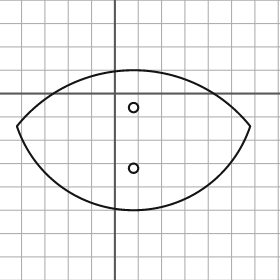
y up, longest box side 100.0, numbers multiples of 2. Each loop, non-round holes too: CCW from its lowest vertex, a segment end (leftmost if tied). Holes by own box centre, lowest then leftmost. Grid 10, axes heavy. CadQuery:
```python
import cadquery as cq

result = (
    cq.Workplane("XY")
    .moveTo(-42.0, -14.0)
    .threePointArc((8.0, -50.0), (58.0, -14.0))
    .threePointArc((8.0, 10.0), (-42.0, -14.0))
    .close()
    .moveTo(8.0, -32.0)
    .circle(2.0)
    .moveTo(8.0, -6.0)
    .circle(2.0)
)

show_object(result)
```